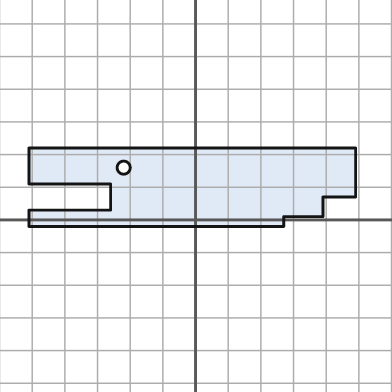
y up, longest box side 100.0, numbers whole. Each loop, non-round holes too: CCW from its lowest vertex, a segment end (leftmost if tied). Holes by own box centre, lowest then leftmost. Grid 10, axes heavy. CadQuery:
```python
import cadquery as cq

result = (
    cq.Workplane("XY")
    .moveTo(-51.0, -2.0)
    .lineTo(27.0, -2.0)
    .lineTo(27.0, 1.0)
    .lineTo(39.0, 1.0)
    .lineTo(39.0, 7.0)
    .lineTo(49.0, 7.0)
    .lineTo(49.0, 22.0)
    .lineTo(-51.0, 22.0)
    .lineTo(-51.0, 11.0)
    .lineTo(-26.0, 11.0)
    .lineTo(-26.0, 3.0)
    .lineTo(-51.0, 3.0)
    .close()
    .moveTo(-22.0, 16.0)
    .circle(2.0)
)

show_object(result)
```